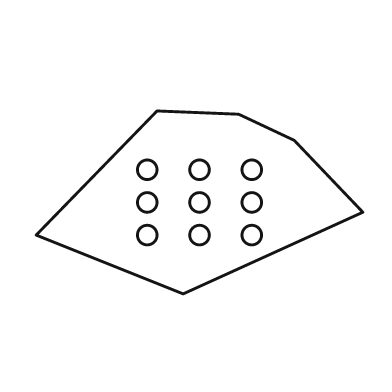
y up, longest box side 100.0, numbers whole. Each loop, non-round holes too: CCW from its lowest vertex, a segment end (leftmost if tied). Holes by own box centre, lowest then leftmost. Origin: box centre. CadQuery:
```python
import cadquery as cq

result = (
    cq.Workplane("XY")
    .moveTo(-5.0, -28.0)
    .lineTo(50.0, -3.0)
    .lineTo(29.0, 19.0)
    .lineTo(12.0, 27.0)
    .lineTo(-13.0, 28.0)
    .lineTo(-50.0, -10.0)
    .close()
    .moveTo(-16.0, -10.0)
    .circle(3.0)
    .moveTo(0.0, -10.0)
    .circle(3.0)
    .moveTo(16.0, -10.0)
    .circle(3.0)
    .moveTo(-16.0, 0.0)
    .circle(3.0)
    .moveTo(0.0, 0.0)
    .circle(3.0)
    .moveTo(16.0, 0.0)
    .circle(3.0)
    .moveTo(-16.0, 10.0)
    .circle(3.0)
    .moveTo(0.0, 10.0)
    .circle(3.0)
    .moveTo(16.0, 10.0)
    .circle(3.0)
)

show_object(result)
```